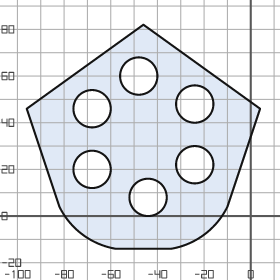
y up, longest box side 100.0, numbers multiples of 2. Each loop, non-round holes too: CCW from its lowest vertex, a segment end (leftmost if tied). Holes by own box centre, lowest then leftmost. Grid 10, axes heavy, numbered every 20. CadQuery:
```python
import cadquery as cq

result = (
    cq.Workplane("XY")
    .moveTo(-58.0, -14.0)
    .lineTo(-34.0, -14.0)
    .threePointArc((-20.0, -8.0), (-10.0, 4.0))
    .lineTo(4.0, 46.0)
    .lineTo(-46.0, 82.0)
    .lineTo(-96.0, 46.0)
    .lineTo(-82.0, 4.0)
    .threePointArc((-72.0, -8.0), (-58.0, -14.0))
    .close()
    .moveTo(-44.0, 8.0)
    .circle(8.0)
    .moveTo(-68.0, 20.0)
    .circle(8.0)
    .moveTo(-24.0, 22.0)
    .circle(8.0)
    .moveTo(-68.0, 46.0)
    .circle(8.0)
    .moveTo(-24.0, 48.0)
    .circle(8.0)
    .moveTo(-48.0, 60.0)
    .circle(8.0)
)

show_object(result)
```